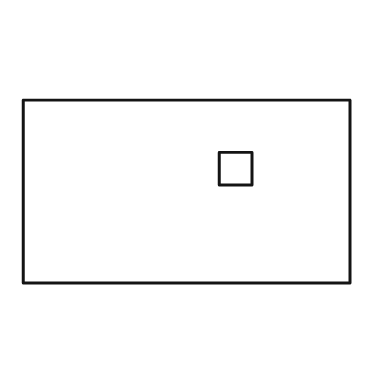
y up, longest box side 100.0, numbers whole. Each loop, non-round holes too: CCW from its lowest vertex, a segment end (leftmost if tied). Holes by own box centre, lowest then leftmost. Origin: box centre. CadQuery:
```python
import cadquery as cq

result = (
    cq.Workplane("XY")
    .moveTo(-50.0, -28.0)
    .lineTo(50.0, -28.0)
    .lineTo(50.0, 28.0)
    .lineTo(-50.0, 28.0)
    .close()
    .moveTo(10.0, 2.0)
    .lineTo(20.0, 2.0)
    .lineTo(20.0, 12.0)
    .lineTo(10.0, 12.0)
    .close()
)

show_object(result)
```